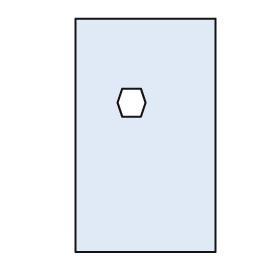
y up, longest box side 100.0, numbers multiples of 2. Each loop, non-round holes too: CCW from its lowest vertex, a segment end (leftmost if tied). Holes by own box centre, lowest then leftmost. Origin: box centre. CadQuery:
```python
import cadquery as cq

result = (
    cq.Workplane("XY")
    .moveTo(-30.0, -50.0)
    .lineTo(30.0, -50.0)
    .lineTo(30.0, 50.0)
    .lineTo(-30.0, 50.0)
    .close()
    .moveTo(-10.0, 8.0)
    .lineTo(-2.0, 8.0)
    .lineTo(0.0, 14.0)
    .lineTo(-2.0, 20.0)
    .lineTo(-10.0, 20.0)
    .lineTo(-12.0, 14.0)
    .close()
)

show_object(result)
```